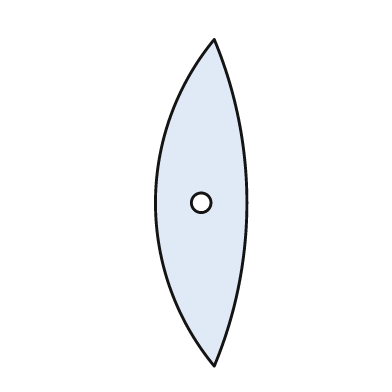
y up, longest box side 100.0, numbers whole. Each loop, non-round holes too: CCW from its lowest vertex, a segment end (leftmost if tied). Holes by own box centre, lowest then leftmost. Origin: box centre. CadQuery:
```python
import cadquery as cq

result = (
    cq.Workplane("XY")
    .moveTo(4.0, -50.0)
    .threePointArc((14.0, 0.0), (4.0, 50.0))
    .threePointArc((-14.0, 0.0), (4.0, -50.0))
    .close()
    .moveTo(0.0, 0.0)
    .circle(3.0)
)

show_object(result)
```